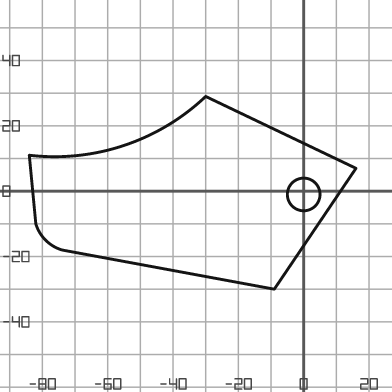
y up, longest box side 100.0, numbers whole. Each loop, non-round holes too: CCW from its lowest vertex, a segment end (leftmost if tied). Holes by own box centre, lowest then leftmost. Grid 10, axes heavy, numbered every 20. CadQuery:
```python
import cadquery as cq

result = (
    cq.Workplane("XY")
    .moveTo(-9.0, -30.0)
    .lineTo(16.0, 7.0)
    .lineTo(-30.0, 29.0)
    .threePointArc((-55.0, 14.0), (-84.0, 11.0))
    .lineTo(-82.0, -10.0)
    .threePointArc((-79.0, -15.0), (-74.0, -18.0))
    .close()
    .moveTo(0.0, -1.0)
    .circle(5.0)
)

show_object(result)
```